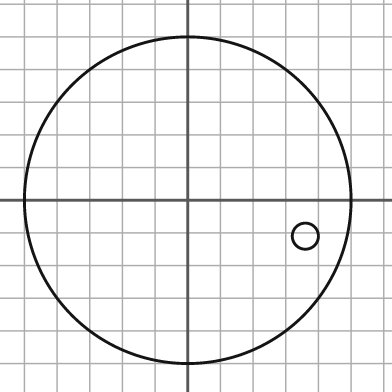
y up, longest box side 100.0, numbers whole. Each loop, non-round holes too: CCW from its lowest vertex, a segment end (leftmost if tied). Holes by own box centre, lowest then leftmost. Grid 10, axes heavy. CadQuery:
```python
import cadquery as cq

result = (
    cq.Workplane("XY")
    .moveTo(0.0, 0.0)
    .circle(50.0)
    .moveTo(36.0, -11.0)
    .circle(4.0)
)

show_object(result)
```